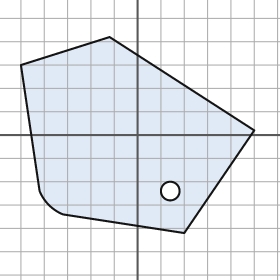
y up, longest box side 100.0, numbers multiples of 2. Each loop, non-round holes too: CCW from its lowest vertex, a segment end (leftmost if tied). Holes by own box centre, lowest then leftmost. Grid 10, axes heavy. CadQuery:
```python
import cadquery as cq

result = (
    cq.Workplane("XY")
    .moveTo(20.0, -42.0)
    .lineTo(50.0, 2.0)
    .lineTo(-12.0, 42.0)
    .lineTo(-50.0, 30.0)
    .lineTo(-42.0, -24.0)
    .threePointArc((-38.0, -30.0), (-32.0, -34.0))
    .close()
    .moveTo(14.0, -24.0)
    .circle(4.0)
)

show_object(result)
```